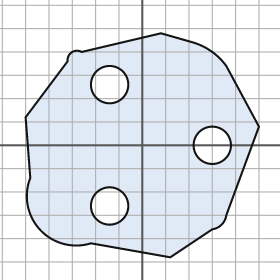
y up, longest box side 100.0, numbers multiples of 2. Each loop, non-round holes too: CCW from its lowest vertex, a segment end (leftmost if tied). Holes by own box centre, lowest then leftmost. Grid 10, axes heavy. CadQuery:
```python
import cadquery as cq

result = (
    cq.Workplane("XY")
    .moveTo(12.0, -48.0)
    .lineTo(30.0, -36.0)
    .threePointArc((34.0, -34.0), (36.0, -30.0))
    .lineTo(50.0, 8.0)
    .lineTo(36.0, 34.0)
    .threePointArc((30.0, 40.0), (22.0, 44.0))
    .lineTo(8.0, 48.0)
    .lineTo(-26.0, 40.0)
    .threePointArc((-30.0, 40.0), (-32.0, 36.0))
    .lineTo(-50.0, 12.0)
    .lineTo(-48.0, -14.0)
    .threePointArc((-44.0, -36.0), (-22.0, -42.0))
    .close()
    .moveTo(-14.0, -26.0)
    .circle(8.0)
    .moveTo(30.0, 0.0)
    .circle(8.0)
    .moveTo(-14.0, 26.0)
    .circle(8.0)
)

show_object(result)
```